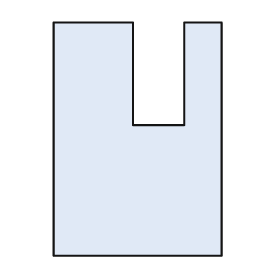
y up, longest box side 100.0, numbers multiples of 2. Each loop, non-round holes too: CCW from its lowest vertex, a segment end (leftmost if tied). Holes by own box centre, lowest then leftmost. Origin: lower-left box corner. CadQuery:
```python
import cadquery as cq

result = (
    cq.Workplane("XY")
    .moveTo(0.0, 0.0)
    .lineTo(72.0, 0.0)
    .lineTo(72.0, 100.0)
    .lineTo(56.0, 100.0)
    .lineTo(56.0, 56.0)
    .lineTo(34.0, 56.0)
    .lineTo(34.0, 100.0)
    .lineTo(0.0, 100.0)
    .close()
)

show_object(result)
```